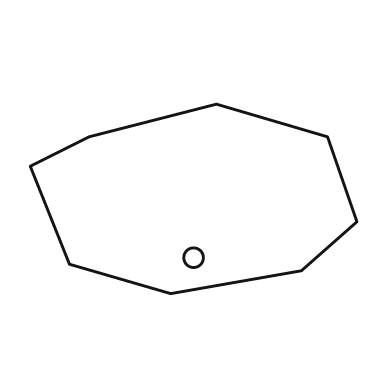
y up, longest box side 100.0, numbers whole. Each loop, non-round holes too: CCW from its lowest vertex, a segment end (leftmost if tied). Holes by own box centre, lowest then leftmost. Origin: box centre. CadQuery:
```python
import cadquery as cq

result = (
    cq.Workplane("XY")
    .moveTo(-7.0, -29.0)
    .lineTo(33.0, -22.0)
    .lineTo(50.0, -7.0)
    .lineTo(41.0, 19.0)
    .lineTo(7.0, 29.0)
    .lineTo(-32.0, 19.0)
    .lineTo(-50.0, 10.0)
    .lineTo(-38.0, -20.0)
    .close()
    .moveTo(0.0, -18.0)
    .circle(3.0)
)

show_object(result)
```